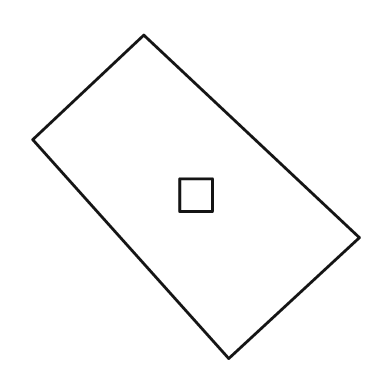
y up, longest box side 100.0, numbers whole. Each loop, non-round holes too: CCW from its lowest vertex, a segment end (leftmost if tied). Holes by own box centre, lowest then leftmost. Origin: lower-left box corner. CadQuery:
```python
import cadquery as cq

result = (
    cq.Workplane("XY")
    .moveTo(60.0, 0.0)
    .lineTo(100.0, 37.0)
    .lineTo(34.0, 99.0)
    .lineTo(0.0, 67.0)
    .close()
    .moveTo(45.0, 45.0)
    .lineTo(55.0, 45.0)
    .lineTo(55.0, 55.0)
    .lineTo(45.0, 55.0)
    .close()
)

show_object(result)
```